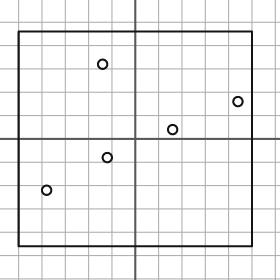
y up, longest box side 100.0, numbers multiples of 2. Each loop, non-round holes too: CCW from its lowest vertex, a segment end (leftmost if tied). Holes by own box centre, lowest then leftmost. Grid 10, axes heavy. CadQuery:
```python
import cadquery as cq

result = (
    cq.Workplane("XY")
    .moveTo(-50.0, -46.0)
    .lineTo(50.0, -46.0)
    .lineTo(50.0, 46.0)
    .lineTo(-50.0, 46.0)
    .close()
    .moveTo(-38.0, -22.0)
    .circle(2.0)
    .moveTo(-12.0, -8.0)
    .circle(2.0)
    .moveTo(16.0, 4.0)
    .circle(2.0)
    .moveTo(44.0, 16.0)
    .circle(2.0)
    .moveTo(-14.0, 32.0)
    .circle(2.0)
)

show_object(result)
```